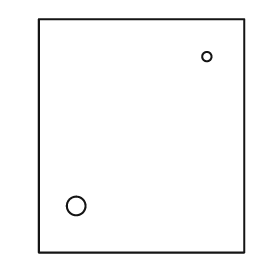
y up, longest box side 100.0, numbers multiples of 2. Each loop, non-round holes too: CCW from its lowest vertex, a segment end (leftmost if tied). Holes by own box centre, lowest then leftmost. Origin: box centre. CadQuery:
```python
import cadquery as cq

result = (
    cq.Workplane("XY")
    .moveTo(-44.0, -50.0)
    .lineTo(44.0, -50.0)
    .lineTo(44.0, 50.0)
    .lineTo(-44.0, 50.0)
    .close()
    .moveTo(-28.0, -30.0)
    .circle(4.0)
    .moveTo(28.0, 34.0)
    .circle(2.0)
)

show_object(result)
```